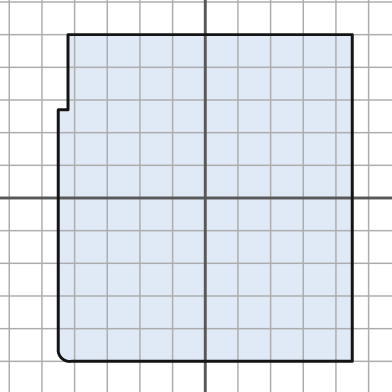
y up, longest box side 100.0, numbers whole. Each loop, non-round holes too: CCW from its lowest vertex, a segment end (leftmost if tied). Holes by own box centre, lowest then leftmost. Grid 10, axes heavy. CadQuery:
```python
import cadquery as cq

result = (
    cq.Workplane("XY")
    .moveTo(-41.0, -50.0)
    .lineTo(45.0, -50.0)
    .lineTo(45.0, 50.0)
    .lineTo(-42.0, 50.0)
    .lineTo(-42.0, 27.0)
    .lineTo(-45.0, 27.0)
    .lineTo(-45.0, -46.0)
    .threePointArc((-44.0, -49.0), (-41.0, -50.0))
    .close()
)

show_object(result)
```